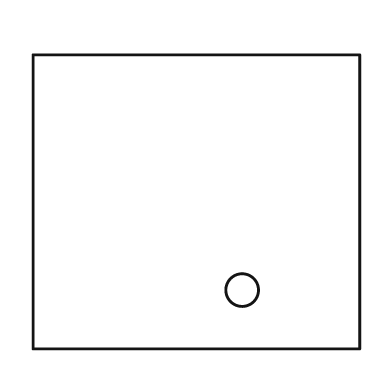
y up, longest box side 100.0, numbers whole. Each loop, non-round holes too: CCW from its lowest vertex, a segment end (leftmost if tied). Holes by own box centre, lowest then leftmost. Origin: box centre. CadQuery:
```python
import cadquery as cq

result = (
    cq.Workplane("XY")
    .moveTo(-50.0, -45.0)
    .lineTo(50.0, -45.0)
    .lineTo(50.0, 45.0)
    .lineTo(-50.0, 45.0)
    .close()
    .moveTo(14.0, -27.0)
    .circle(5.0)
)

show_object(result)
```